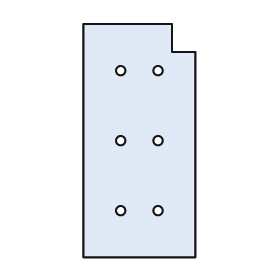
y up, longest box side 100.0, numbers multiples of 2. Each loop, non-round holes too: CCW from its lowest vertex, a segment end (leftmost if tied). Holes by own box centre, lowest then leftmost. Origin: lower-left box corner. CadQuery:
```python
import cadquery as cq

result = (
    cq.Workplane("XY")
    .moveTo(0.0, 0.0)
    .lineTo(48.0, 0.0)
    .lineTo(48.0, 88.0)
    .lineTo(38.0, 88.0)
    .lineTo(38.0, 100.0)
    .lineTo(0.0, 100.0)
    .close()
    .moveTo(16.0, 20.0)
    .circle(2.0)
    .moveTo(32.0, 20.0)
    .circle(2.0)
    .moveTo(16.0, 50.0)
    .circle(2.0)
    .moveTo(32.0, 50.0)
    .circle(2.0)
    .moveTo(16.0, 80.0)
    .circle(2.0)
    .moveTo(32.0, 80.0)
    .circle(2.0)
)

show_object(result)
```